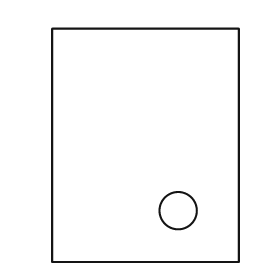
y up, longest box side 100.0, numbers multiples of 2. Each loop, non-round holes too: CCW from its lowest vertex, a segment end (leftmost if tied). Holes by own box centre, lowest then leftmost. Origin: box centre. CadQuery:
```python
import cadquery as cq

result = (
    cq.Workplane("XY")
    .moveTo(-40.0, -50.0)
    .lineTo(40.0, -50.0)
    .lineTo(40.0, 50.0)
    .lineTo(-40.0, 50.0)
    .close()
    .moveTo(14.0, -28.0)
    .circle(8.0)
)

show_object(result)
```